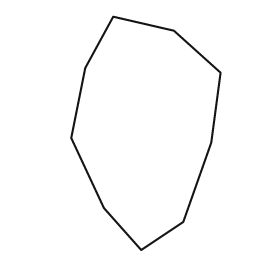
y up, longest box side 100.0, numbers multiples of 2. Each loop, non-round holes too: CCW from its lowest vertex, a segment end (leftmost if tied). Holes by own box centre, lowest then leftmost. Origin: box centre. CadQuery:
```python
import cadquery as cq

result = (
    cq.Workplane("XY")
    .moveTo(-2.0, -50.0)
    .lineTo(16.0, -38.0)
    .lineTo(28.0, -4.0)
    .lineTo(32.0, 26.0)
    .lineTo(12.0, 44.0)
    .lineTo(-14.0, 50.0)
    .lineTo(-26.0, 28.0)
    .lineTo(-32.0, -2.0)
    .lineTo(-18.0, -32.0)
    .close()
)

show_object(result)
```